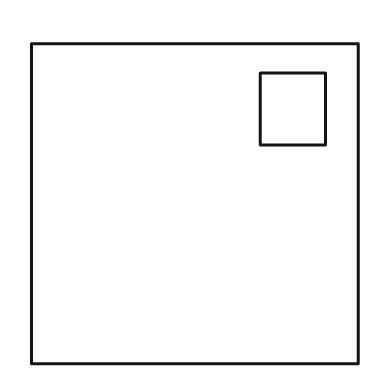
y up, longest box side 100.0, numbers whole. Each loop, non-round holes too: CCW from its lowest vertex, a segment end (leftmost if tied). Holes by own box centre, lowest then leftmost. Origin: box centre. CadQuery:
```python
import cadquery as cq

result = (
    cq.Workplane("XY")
    .moveTo(-50.0, -49.0)
    .lineTo(50.0, -49.0)
    .lineTo(50.0, 49.0)
    .lineTo(-50.0, 49.0)
    .close()
    .moveTo(20.0, 18.0)
    .lineTo(40.0, 18.0)
    .lineTo(40.0, 40.0)
    .lineTo(20.0, 40.0)
    .close()
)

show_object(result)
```